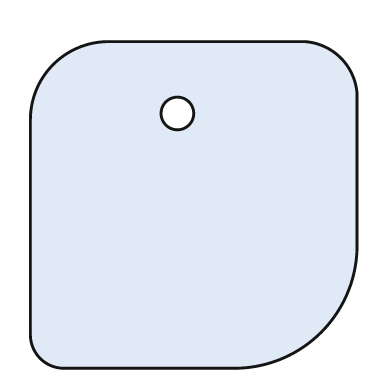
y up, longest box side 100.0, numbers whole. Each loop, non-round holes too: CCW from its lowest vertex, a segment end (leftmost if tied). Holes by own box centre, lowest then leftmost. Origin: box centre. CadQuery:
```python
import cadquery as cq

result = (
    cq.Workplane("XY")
    .moveTo(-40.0, -50.0)
    .lineTo(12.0, -50.0)
    .threePointArc((39.0, -39.0), (50.0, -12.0))
    .lineTo(50.0, 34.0)
    .threePointArc((45.0, 45.0), (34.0, 50.0))
    .lineTo(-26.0, 50.0)
    .threePointArc((-43.0, 43.0), (-50.0, 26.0))
    .lineTo(-50.0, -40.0)
    .threePointArc((-47.0, -47.0), (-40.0, -50.0))
    .close()
    .moveTo(-5.0, 28.0)
    .circle(5.0)
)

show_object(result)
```